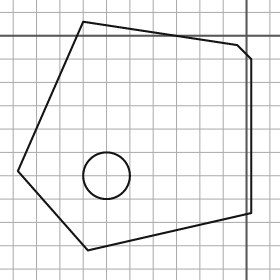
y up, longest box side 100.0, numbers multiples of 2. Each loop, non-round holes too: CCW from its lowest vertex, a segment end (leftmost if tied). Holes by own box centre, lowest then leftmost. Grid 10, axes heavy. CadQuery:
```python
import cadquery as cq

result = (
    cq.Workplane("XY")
    .moveTo(-68.0, -92.0)
    .lineTo(2.0, -76.0)
    .lineTo(2.0, -10.0)
    .lineTo(-4.0, -4.0)
    .lineTo(-70.0, 6.0)
    .lineTo(-98.0, -58.0)
    .close()
    .moveTo(-60.0, -60.0)
    .circle(10.0)
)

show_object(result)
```